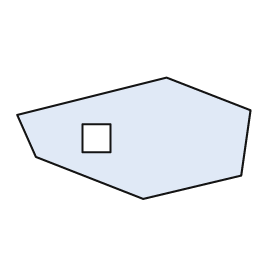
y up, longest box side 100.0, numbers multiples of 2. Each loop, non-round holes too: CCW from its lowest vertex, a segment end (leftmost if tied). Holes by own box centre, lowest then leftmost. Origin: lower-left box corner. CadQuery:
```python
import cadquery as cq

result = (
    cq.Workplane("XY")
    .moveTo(54.0, 0.0)
    .lineTo(96.0, 10.0)
    .lineTo(100.0, 38.0)
    .lineTo(64.0, 52.0)
    .lineTo(0.0, 36.0)
    .lineTo(8.0, 18.0)
    .close()
    .moveTo(28.0, 20.0)
    .lineTo(40.0, 20.0)
    .lineTo(40.0, 32.0)
    .lineTo(28.0, 32.0)
    .close()
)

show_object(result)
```